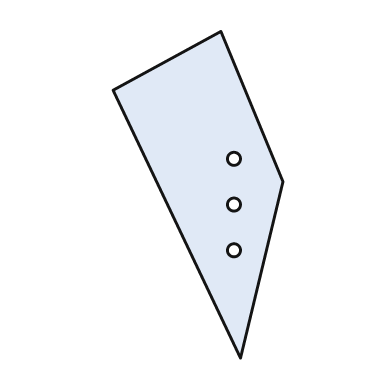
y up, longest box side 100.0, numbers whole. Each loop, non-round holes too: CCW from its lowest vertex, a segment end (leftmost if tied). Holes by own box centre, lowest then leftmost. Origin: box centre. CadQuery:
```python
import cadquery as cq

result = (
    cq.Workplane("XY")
    .moveTo(13.0, -50.0)
    .lineTo(26.0, 4.0)
    .lineTo(7.0, 50.0)
    .lineTo(-26.0, 32.0)
    .close()
    .moveTo(11.0, -17.0)
    .circle(2.0)
    .moveTo(11.0, -3.0)
    .circle(2.0)
    .moveTo(11.0, 11.0)
    .circle(2.0)
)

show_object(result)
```